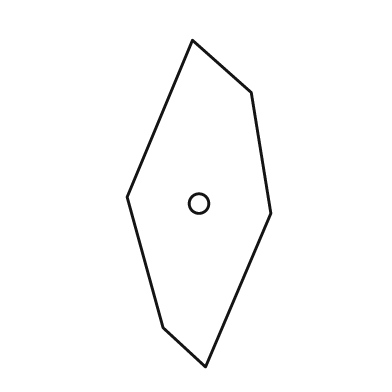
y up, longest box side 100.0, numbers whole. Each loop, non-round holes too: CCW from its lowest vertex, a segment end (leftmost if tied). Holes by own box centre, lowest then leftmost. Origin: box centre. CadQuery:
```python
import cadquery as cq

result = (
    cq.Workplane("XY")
    .moveTo(2.0, -50.0)
    .lineTo(22.0, -3.0)
    .lineTo(16.0, 34.0)
    .lineTo(-2.0, 50.0)
    .lineTo(-22.0, 2.0)
    .lineTo(-11.0, -38.0)
    .close()
    .moveTo(0.0, 0.0)
    .circle(3.0)
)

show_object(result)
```